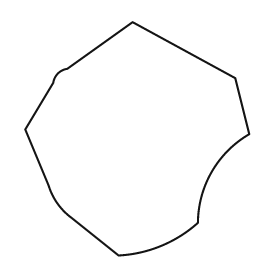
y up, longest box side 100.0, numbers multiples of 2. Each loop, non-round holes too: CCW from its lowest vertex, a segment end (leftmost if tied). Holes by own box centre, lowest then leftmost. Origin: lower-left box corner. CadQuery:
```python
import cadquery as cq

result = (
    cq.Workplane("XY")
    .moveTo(40.0, 0.0)
    .threePointArc((58.0, 4.0), (74.0, 14.0))
    .threePointArc((80.0, 36.0), (96.0, 52.0))
    .lineTo(90.0, 76.0)
    .lineTo(46.0, 100.0)
    .lineTo(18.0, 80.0)
    .threePointArc((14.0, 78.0), (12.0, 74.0))
    .lineTo(0.0, 54.0)
    .lineTo(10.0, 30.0)
    .threePointArc((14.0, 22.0), (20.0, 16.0))
    .close()
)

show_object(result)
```